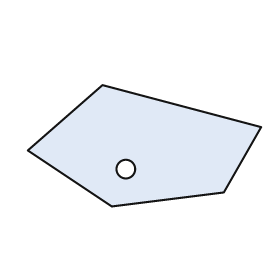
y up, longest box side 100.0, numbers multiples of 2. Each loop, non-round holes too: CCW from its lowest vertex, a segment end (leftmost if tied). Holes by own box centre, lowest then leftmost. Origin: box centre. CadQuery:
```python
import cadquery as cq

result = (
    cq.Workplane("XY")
    .moveTo(-14.0, -26.0)
    .lineTo(34.0, -20.0)
    .lineTo(50.0, 8.0)
    .lineTo(-18.0, 26.0)
    .lineTo(-50.0, -2.0)
    .close()
    .moveTo(-8.0, -10.0)
    .circle(4.0)
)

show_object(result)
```